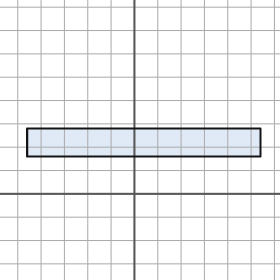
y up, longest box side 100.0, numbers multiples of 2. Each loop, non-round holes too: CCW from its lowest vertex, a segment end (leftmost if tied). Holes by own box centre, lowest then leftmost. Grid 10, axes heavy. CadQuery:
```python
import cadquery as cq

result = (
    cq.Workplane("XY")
    .moveTo(-46.0, 16.0)
    .lineTo(54.0, 16.0)
    .lineTo(54.0, 28.0)
    .lineTo(-46.0, 28.0)
    .close()
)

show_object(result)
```